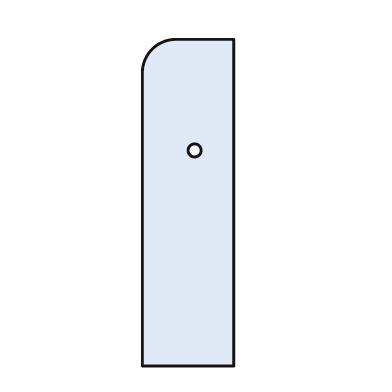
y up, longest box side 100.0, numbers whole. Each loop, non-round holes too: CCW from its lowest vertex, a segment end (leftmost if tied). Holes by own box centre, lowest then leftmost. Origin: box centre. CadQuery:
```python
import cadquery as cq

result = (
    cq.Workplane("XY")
    .moveTo(-14.0, -50.0)
    .lineTo(14.0, -50.0)
    .lineTo(14.0, 50.0)
    .lineTo(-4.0, 50.0)
    .threePointArc((-11.0, 47.0), (-14.0, 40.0))
    .close()
    .moveTo(2.0, 16.0)
    .circle(2.0)
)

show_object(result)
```